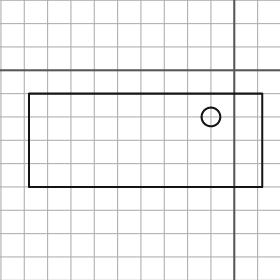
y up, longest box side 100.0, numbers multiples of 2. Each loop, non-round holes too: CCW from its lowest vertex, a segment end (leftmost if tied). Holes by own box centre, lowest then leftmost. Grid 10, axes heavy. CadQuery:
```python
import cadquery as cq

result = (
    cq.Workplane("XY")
    .moveTo(-88.0, -50.0)
    .lineTo(12.0, -50.0)
    .lineTo(12.0, -10.0)
    .lineTo(-88.0, -10.0)
    .close()
    .moveTo(-10.0, -20.0)
    .circle(4.0)
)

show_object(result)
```